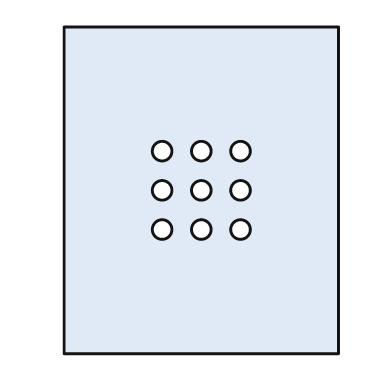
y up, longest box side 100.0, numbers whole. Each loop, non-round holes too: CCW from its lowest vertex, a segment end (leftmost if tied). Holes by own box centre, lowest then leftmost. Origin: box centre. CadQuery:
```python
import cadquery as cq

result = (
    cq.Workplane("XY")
    .moveTo(-42.0, -50.0)
    .lineTo(42.0, -50.0)
    .lineTo(42.0, 50.0)
    .lineTo(-42.0, 50.0)
    .close()
    .moveTo(-12.0, -12.0)
    .circle(3.0)
    .moveTo(0.0, -12.0)
    .circle(3.0)
    .moveTo(12.0, -12.0)
    .circle(3.0)
    .moveTo(-12.0, 0.0)
    .circle(3.0)
    .moveTo(0.0, 0.0)
    .circle(3.0)
    .moveTo(12.0, 0.0)
    .circle(3.0)
    .moveTo(-12.0, 12.0)
    .circle(3.0)
    .moveTo(0.0, 12.0)
    .circle(3.0)
    .moveTo(12.0, 12.0)
    .circle(3.0)
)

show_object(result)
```